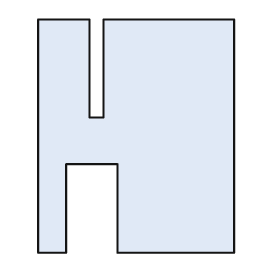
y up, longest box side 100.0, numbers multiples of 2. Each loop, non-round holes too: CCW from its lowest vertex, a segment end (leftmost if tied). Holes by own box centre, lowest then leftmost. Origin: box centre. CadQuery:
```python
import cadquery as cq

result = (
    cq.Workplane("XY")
    .moveTo(-42.0, -50.0)
    .lineTo(-30.0, -50.0)
    .lineTo(-30.0, -12.0)
    .lineTo(-8.0, -12.0)
    .lineTo(-8.0, -50.0)
    .lineTo(42.0, -50.0)
    .lineTo(42.0, 50.0)
    .lineTo(-14.0, 50.0)
    .lineTo(-14.0, 8.0)
    .lineTo(-20.0, 8.0)
    .lineTo(-20.0, 50.0)
    .lineTo(-42.0, 50.0)
    .close()
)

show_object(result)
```